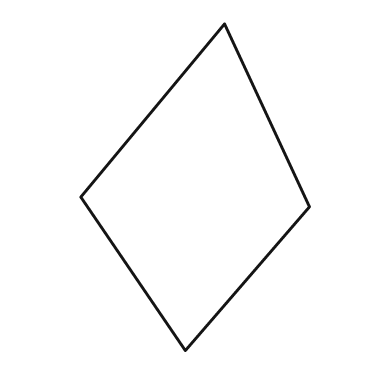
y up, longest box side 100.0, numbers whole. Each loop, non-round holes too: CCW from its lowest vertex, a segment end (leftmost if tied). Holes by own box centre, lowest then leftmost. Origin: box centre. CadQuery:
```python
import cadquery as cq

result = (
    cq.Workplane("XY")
    .moveTo(-3.0, -50.0)
    .lineTo(35.0, -6.0)
    .lineTo(9.0, 50.0)
    .lineTo(-35.0, -3.0)
    .close()
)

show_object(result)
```